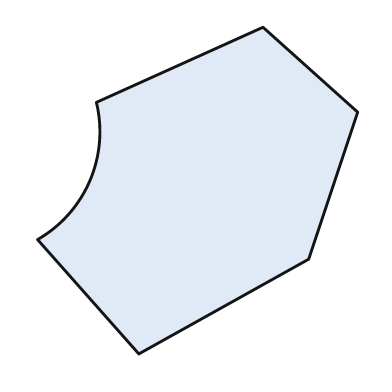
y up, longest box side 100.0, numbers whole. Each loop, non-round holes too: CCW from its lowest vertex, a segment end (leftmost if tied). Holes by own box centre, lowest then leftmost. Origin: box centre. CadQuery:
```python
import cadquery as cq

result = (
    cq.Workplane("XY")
    .moveTo(-18.0, -50.0)
    .lineTo(34.0, -21.0)
    .lineTo(49.0, 24.0)
    .lineTo(20.0, 50.0)
    .lineTo(-31.0, 27.0)
    .threePointArc((-33.0, 3.0), (-49.0, -15.0))
    .close()
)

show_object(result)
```